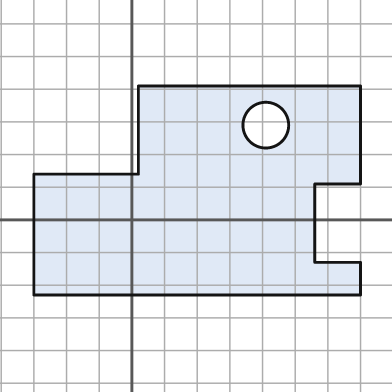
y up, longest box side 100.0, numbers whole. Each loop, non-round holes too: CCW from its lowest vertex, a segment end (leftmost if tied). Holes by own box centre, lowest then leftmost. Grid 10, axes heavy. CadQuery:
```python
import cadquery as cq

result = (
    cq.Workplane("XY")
    .moveTo(-30.0, -23.0)
    .lineTo(70.0, -23.0)
    .lineTo(70.0, -13.0)
    .lineTo(56.0, -13.0)
    .lineTo(56.0, 11.0)
    .lineTo(70.0, 11.0)
    .lineTo(70.0, 41.0)
    .lineTo(2.0, 41.0)
    .lineTo(2.0, 14.0)
    .lineTo(-30.0, 14.0)
    .close()
    .moveTo(41.0, 29.0)
    .circle(7.0)
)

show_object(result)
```